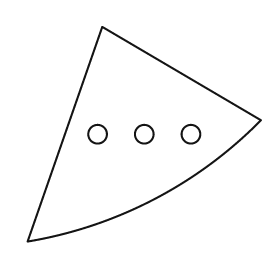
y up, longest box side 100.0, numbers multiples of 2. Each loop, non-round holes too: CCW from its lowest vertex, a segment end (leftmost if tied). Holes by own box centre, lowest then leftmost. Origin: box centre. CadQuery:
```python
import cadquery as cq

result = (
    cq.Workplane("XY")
    .moveTo(-50.0, -46.0)
    .threePointArc((4.0, -28.0), (50.0, 6.0))
    .lineTo(-18.0, 46.0)
    .close()
    .moveTo(-20.0, 0.0)
    .circle(4.0)
    .moveTo(0.0, 0.0)
    .circle(4.0)
    .moveTo(20.0, 0.0)
    .circle(4.0)
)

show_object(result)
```